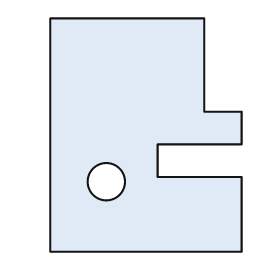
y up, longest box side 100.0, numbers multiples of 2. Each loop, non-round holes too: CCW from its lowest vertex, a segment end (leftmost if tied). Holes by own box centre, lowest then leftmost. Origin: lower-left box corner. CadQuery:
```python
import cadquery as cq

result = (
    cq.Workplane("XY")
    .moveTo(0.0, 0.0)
    .lineTo(82.0, 0.0)
    .lineTo(82.0, 32.0)
    .lineTo(46.0, 32.0)
    .lineTo(46.0, 46.0)
    .lineTo(82.0, 46.0)
    .lineTo(82.0, 60.0)
    .lineTo(66.0, 60.0)
    .lineTo(66.0, 100.0)
    .lineTo(0.0, 100.0)
    .close()
    .moveTo(24.0, 30.0)
    .circle(8.0)
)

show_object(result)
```